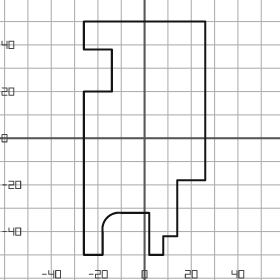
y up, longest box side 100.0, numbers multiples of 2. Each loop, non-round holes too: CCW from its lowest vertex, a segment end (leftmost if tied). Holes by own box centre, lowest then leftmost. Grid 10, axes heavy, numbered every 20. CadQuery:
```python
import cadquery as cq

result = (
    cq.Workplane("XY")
    .moveTo(-26.0, -50.0)
    .lineTo(-18.0, -50.0)
    .lineTo(-18.0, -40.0)
    .threePointArc((-16.0, -34.0), (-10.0, -32.0))
    .lineTo(2.0, -32.0)
    .lineTo(2.0, -50.0)
    .lineTo(8.0, -50.0)
    .lineTo(8.0, -42.0)
    .lineTo(14.0, -42.0)
    .lineTo(14.0, -18.0)
    .lineTo(26.0, -18.0)
    .lineTo(26.0, 50.0)
    .lineTo(-26.0, 50.0)
    .lineTo(-26.0, 38.0)
    .lineTo(-14.0, 38.0)
    .lineTo(-14.0, 20.0)
    .lineTo(-26.0, 20.0)
    .close()
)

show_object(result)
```